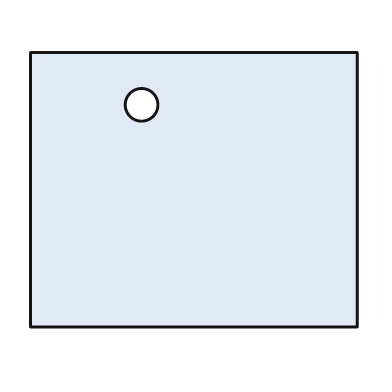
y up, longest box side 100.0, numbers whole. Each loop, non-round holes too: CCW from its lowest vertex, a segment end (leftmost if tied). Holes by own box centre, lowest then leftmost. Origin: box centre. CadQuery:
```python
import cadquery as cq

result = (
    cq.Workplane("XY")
    .moveTo(-50.0, -42.0)
    .lineTo(50.0, -42.0)
    .lineTo(50.0, 42.0)
    .lineTo(-50.0, 42.0)
    .close()
    .moveTo(-16.0, 26.0)
    .circle(5.0)
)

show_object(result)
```